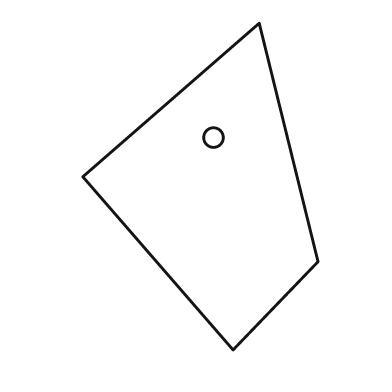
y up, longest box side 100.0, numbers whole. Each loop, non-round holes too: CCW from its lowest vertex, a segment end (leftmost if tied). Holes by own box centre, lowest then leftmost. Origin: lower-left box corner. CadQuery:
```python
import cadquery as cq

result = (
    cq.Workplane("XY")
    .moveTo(46.0, 0.0)
    .lineTo(72.0, 27.0)
    .lineTo(54.0, 100.0)
    .lineTo(0.0, 53.0)
    .close()
    .moveTo(40.0, 65.0)
    .circle(3.0)
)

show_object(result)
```